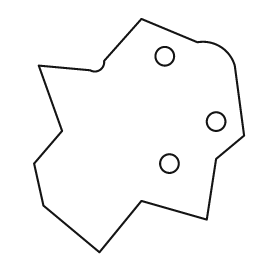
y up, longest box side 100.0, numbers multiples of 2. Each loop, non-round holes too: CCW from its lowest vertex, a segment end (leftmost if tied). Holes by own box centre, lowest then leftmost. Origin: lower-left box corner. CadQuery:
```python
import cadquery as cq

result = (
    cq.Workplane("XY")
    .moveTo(28.0, 0.0)
    .lineTo(46.0, 22.0)
    .lineTo(74.0, 14.0)
    .lineTo(78.0, 40.0)
    .lineTo(90.0, 50.0)
    .lineTo(86.0, 80.0)
    .threePointArc((80.0, 88.0), (70.0, 90.0))
    .lineTo(46.0, 100.0)
    .lineTo(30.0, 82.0)
    .threePointArc((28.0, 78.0), (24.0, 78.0))
    .lineTo(2.0, 80.0)
    .lineTo(12.0, 52.0)
    .lineTo(0.0, 38.0)
    .lineTo(4.0, 20.0)
    .close()
    .moveTo(58.0, 38.0)
    .circle(4.0)
    .moveTo(78.0, 56.0)
    .circle(4.0)
    .moveTo(56.0, 84.0)
    .circle(4.0)
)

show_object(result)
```